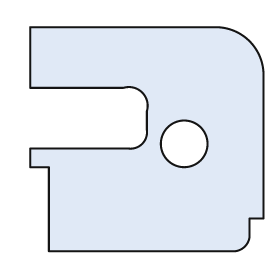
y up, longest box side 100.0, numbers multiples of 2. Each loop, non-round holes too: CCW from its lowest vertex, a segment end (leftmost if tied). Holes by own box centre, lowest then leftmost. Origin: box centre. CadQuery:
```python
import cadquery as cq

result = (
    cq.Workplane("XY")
    .moveTo(-42.0, -48.0)
    .lineTo(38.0, -48.0)
    .threePointArc((42.0, -46.0), (44.0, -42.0))
    .lineTo(44.0, -34.0)
    .lineTo(50.0, -34.0)
    .lineTo(50.0, 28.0)
    .threePointArc((44.0, 42.0), (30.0, 48.0))
    .lineTo(-50.0, 48.0)
    .lineTo(-50.0, 22.0)
    .lineTo(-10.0, 22.0)
    .threePointArc((-2.0, 20.0), (0.0, 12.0))
    .lineTo(0.0, 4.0)
    .threePointArc((-2.0, -2.0), (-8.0, -4.0))
    .lineTo(-50.0, -4.0)
    .lineTo(-50.0, -12.0)
    .lineTo(-42.0, -12.0)
    .close()
    .moveTo(16.0, -2.0)
    .circle(10.0)
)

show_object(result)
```